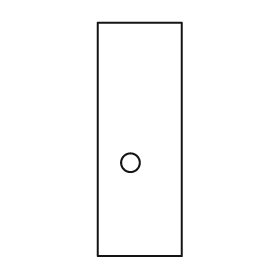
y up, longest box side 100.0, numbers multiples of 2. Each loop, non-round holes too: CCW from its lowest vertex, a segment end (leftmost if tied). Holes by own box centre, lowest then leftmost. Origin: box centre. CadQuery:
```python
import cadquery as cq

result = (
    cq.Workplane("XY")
    .moveTo(-18.0, -50.0)
    .lineTo(18.0, -50.0)
    .lineTo(18.0, 50.0)
    .lineTo(-18.0, 50.0)
    .close()
    .moveTo(-4.0, -10.0)
    .circle(4.0)
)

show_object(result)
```